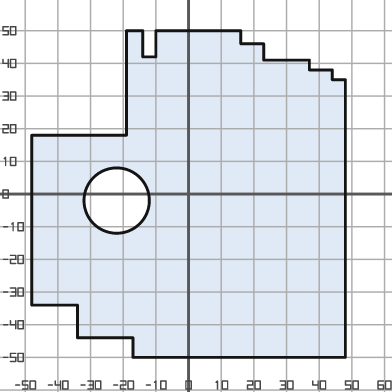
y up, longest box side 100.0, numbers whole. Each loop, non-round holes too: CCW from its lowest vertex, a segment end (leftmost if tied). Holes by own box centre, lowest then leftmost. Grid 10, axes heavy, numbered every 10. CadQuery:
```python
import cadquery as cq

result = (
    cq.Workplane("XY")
    .moveTo(-17.0, -50.0)
    .lineTo(48.0, -50.0)
    .lineTo(48.0, 35.0)
    .lineTo(44.0, 35.0)
    .lineTo(44.0, 38.0)
    .lineTo(37.0, 38.0)
    .lineTo(37.0, 41.0)
    .lineTo(23.0, 41.0)
    .lineTo(23.0, 46.0)
    .lineTo(16.0, 46.0)
    .lineTo(16.0, 50.0)
    .lineTo(-10.0, 50.0)
    .lineTo(-10.0, 42.0)
    .lineTo(-14.0, 42.0)
    .lineTo(-14.0, 50.0)
    .lineTo(-19.0, 50.0)
    .lineTo(-19.0, 18.0)
    .lineTo(-48.0, 18.0)
    .lineTo(-48.0, -34.0)
    .lineTo(-34.0, -34.0)
    .lineTo(-34.0, -44.0)
    .lineTo(-17.0, -44.0)
    .close()
    .moveTo(-22.0, -2.0)
    .circle(10.0)
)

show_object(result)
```